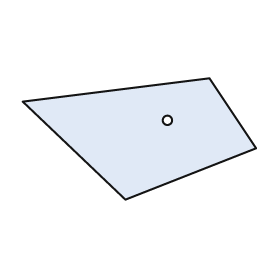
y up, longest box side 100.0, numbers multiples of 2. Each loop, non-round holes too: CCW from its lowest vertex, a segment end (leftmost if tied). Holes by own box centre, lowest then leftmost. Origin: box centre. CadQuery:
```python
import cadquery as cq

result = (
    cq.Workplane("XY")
    .moveTo(-6.0, -26.0)
    .lineTo(50.0, -4.0)
    .lineTo(30.0, 26.0)
    .lineTo(-50.0, 16.0)
    .close()
    .moveTo(12.0, 8.0)
    .circle(2.0)
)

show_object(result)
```